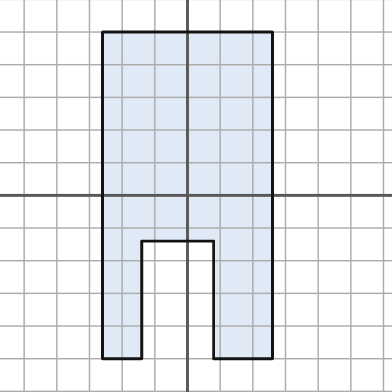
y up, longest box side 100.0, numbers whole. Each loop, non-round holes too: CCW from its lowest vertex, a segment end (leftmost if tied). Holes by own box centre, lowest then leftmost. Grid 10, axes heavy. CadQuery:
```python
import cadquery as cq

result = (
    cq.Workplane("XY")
    .moveTo(-26.0, -50.0)
    .lineTo(-14.0, -50.0)
    .lineTo(-14.0, -14.0)
    .lineTo(8.0, -14.0)
    .lineTo(8.0, -50.0)
    .lineTo(26.0, -50.0)
    .lineTo(26.0, 50.0)
    .lineTo(-26.0, 50.0)
    .close()
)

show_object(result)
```